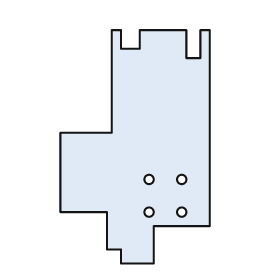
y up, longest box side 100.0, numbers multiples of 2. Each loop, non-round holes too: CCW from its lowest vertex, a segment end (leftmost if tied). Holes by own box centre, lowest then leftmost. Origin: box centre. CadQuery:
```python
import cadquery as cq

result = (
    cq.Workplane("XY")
    .moveTo(-6.0, -50.0)
    .lineTo(8.0, -50.0)
    .lineTo(8.0, -34.0)
    .lineTo(32.0, -34.0)
    .lineTo(32.0, 50.0)
    .lineTo(28.0, 50.0)
    .lineTo(28.0, 38.0)
    .lineTo(22.0, 38.0)
    .lineTo(22.0, 50.0)
    .lineTo(2.0, 50.0)
    .lineTo(2.0, 42.0)
    .lineTo(-6.0, 42.0)
    .lineTo(-6.0, 50.0)
    .lineTo(-10.0, 50.0)
    .lineTo(-10.0, 6.0)
    .lineTo(-32.0, 6.0)
    .lineTo(-32.0, -28.0)
    .lineTo(-12.0, -28.0)
    .lineTo(-12.0, -44.0)
    .lineTo(-6.0, -44.0)
    .close()
    .moveTo(6.0, -28.0)
    .circle(2.0)
    .moveTo(20.0, -28.0)
    .circle(2.0)
    .moveTo(6.0, -14.0)
    .circle(2.0)
    .moveTo(20.0, -14.0)
    .circle(2.0)
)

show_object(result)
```